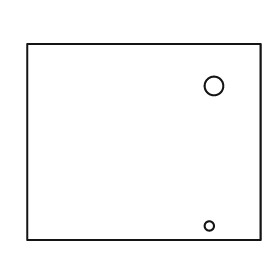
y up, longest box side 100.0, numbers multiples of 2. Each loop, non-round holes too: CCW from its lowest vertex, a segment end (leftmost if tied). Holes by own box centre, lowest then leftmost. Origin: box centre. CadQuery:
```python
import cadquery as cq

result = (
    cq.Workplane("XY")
    .moveTo(-50.0, -42.0)
    .lineTo(50.0, -42.0)
    .lineTo(50.0, 42.0)
    .lineTo(-50.0, 42.0)
    .close()
    .moveTo(28.0, -36.0)
    .circle(2.0)
    .moveTo(30.0, 24.0)
    .circle(4.0)
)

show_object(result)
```